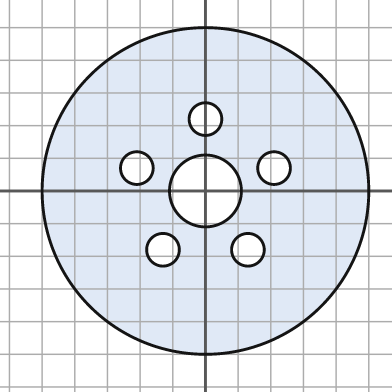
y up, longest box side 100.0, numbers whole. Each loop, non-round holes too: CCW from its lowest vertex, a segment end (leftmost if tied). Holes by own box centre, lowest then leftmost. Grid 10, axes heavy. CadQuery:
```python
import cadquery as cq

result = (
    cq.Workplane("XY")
    .moveTo(0.0, 0.0)
    .circle(50.0)
    .moveTo(-13.0, -18.0)
    .circle(5.0)
    .moveTo(13.0, -18.0)
    .circle(5.0)
    .moveTo(0.0, 0.0)
    .circle(11.0)
    .moveTo(-21.0, 7.0)
    .circle(5.0)
    .moveTo(21.0, 7.0)
    .circle(5.0)
    .moveTo(0.0, 22.0)
    .circle(5.0)
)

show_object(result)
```